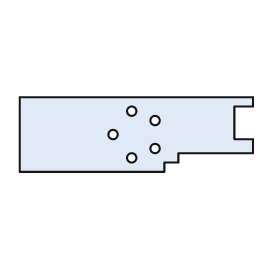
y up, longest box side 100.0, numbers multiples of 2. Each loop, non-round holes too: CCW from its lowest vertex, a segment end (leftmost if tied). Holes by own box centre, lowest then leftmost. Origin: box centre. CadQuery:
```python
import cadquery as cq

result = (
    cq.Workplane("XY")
    .moveTo(-50.0, -16.0)
    .lineTo(12.0, -16.0)
    .lineTo(12.0, -12.0)
    .lineTo(18.0, -12.0)
    .lineTo(18.0, -8.0)
    .lineTo(50.0, -8.0)
    .lineTo(50.0, -2.0)
    .lineTo(42.0, -2.0)
    .lineTo(42.0, 12.0)
    .lineTo(50.0, 12.0)
    .lineTo(50.0, 16.0)
    .lineTo(-50.0, 16.0)
    .close()
    .moveTo(-2.0, -10.0)
    .circle(2.0)
    .moveTo(8.0, -6.0)
    .circle(2.0)
    .moveTo(-10.0, 0.0)
    .circle(2.0)
    .moveTo(8.0, 6.0)
    .circle(2.0)
    .moveTo(-2.0, 10.0)
    .circle(2.0)
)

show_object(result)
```